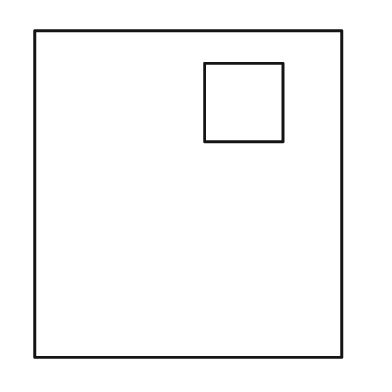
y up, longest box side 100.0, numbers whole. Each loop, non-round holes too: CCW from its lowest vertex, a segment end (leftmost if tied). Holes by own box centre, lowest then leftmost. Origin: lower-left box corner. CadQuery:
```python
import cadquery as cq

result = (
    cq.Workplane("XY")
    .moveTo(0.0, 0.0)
    .lineTo(94.0, 0.0)
    .lineTo(94.0, 100.0)
    .lineTo(0.0, 100.0)
    .close()
    .moveTo(52.0, 66.0)
    .lineTo(76.0, 66.0)
    .lineTo(76.0, 90.0)
    .lineTo(52.0, 90.0)
    .close()
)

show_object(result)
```